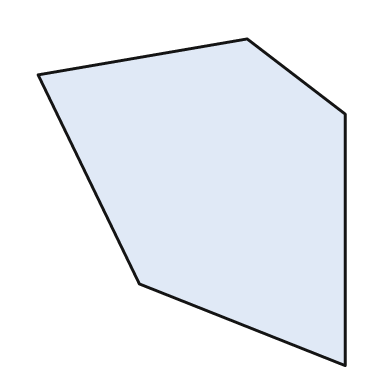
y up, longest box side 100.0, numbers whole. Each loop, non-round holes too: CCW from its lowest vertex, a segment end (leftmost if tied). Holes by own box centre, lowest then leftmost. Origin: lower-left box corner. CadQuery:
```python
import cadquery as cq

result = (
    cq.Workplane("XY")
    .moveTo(94.0, 0.0)
    .lineTo(94.0, 77.0)
    .lineTo(64.0, 100.0)
    .lineTo(0.0, 89.0)
    .lineTo(31.0, 25.0)
    .close()
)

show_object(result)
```